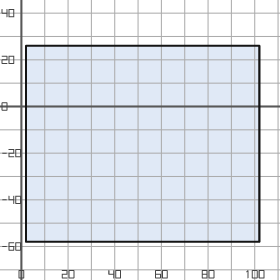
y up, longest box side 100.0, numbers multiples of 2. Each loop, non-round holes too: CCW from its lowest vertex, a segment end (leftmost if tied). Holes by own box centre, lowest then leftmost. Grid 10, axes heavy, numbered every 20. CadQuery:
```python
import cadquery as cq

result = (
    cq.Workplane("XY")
    .moveTo(2.0, -58.0)
    .lineTo(102.0, -58.0)
    .lineTo(102.0, 26.0)
    .lineTo(2.0, 26.0)
    .close()
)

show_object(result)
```